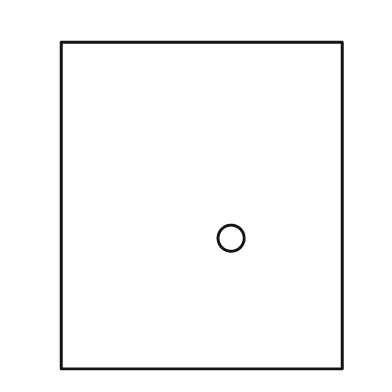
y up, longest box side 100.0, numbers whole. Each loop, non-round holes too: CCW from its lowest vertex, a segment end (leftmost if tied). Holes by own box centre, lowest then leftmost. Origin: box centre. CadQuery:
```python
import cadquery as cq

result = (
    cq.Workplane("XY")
    .moveTo(-43.0, -50.0)
    .lineTo(43.0, -50.0)
    .lineTo(43.0, 50.0)
    .lineTo(-43.0, 50.0)
    .close()
    .moveTo(9.0, -10.0)
    .circle(4.0)
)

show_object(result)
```